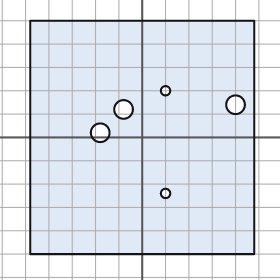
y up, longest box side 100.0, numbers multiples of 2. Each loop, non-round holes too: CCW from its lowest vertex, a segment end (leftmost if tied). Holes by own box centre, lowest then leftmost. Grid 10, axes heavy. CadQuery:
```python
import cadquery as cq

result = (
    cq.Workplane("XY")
    .moveTo(-48.0, -50.0)
    .lineTo(48.0, -50.0)
    .lineTo(48.0, 50.0)
    .lineTo(-48.0, 50.0)
    .close()
    .moveTo(10.0, -24.0)
    .circle(2.0)
    .moveTo(-18.0, 2.0)
    .circle(4.0)
    .moveTo(-8.0, 12.0)
    .circle(4.0)
    .moveTo(40.0, 14.0)
    .circle(4.0)
    .moveTo(10.0, 20.0)
    .circle(2.0)
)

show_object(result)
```